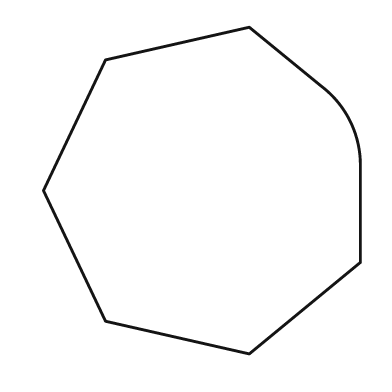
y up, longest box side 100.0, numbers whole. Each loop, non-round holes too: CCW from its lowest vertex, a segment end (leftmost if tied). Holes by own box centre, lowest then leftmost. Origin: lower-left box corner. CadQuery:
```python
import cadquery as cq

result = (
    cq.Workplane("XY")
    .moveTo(63.0, 0.0)
    .lineTo(97.0, 28.0)
    .lineTo(97.0, 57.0)
    .threePointArc((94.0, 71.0), (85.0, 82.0))
    .lineTo(63.0, 100.0)
    .lineTo(19.0, 90.0)
    .lineTo(0.0, 50.0)
    .lineTo(19.0, 10.0)
    .close()
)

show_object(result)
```